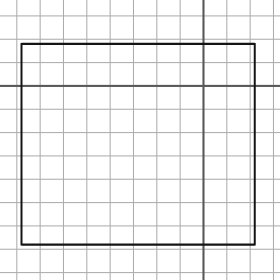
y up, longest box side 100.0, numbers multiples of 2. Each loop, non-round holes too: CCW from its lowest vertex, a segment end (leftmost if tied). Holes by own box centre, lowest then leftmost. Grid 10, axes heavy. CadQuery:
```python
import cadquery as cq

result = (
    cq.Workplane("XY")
    .moveTo(-78.0, -68.0)
    .lineTo(22.0, -68.0)
    .lineTo(22.0, 18.0)
    .lineTo(-78.0, 18.0)
    .close()
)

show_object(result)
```